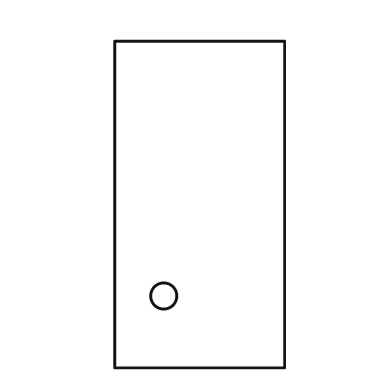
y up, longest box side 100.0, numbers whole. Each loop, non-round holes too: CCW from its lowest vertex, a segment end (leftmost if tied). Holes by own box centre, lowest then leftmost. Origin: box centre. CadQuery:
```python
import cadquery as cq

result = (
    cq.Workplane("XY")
    .moveTo(-26.0, -50.0)
    .lineTo(26.0, -50.0)
    .lineTo(26.0, 50.0)
    .lineTo(-26.0, 50.0)
    .close()
    .moveTo(-11.0, -28.0)
    .circle(4.0)
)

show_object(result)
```